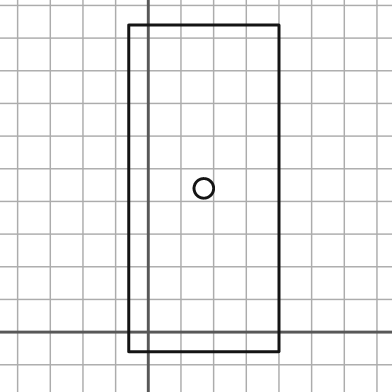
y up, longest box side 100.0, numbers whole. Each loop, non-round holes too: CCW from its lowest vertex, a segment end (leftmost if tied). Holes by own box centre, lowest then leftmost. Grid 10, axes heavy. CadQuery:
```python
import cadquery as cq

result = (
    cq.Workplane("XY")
    .moveTo(-6.0, -6.0)
    .lineTo(40.0, -6.0)
    .lineTo(40.0, 94.0)
    .lineTo(-6.0, 94.0)
    .close()
    .moveTo(17.0, 44.0)
    .circle(3.0)
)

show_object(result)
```